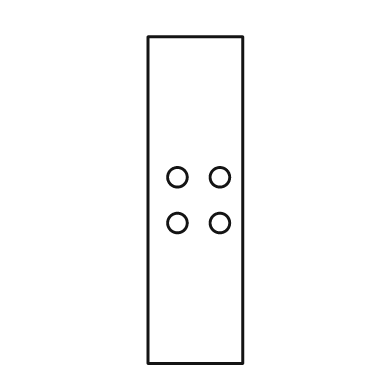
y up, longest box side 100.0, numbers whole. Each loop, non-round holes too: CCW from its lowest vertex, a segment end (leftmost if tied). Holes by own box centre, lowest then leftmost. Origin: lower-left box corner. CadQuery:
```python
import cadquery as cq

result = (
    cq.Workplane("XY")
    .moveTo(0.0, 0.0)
    .lineTo(29.0, 0.0)
    .lineTo(29.0, 100.0)
    .lineTo(0.0, 100.0)
    .close()
    .moveTo(9.0, 43.0)
    .circle(3.0)
    .moveTo(22.0, 43.0)
    .circle(3.0)
    .moveTo(9.0, 57.0)
    .circle(3.0)
    .moveTo(22.0, 57.0)
    .circle(3.0)
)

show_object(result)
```